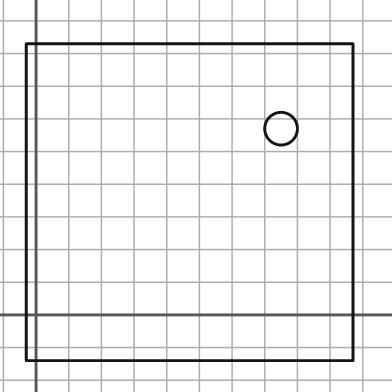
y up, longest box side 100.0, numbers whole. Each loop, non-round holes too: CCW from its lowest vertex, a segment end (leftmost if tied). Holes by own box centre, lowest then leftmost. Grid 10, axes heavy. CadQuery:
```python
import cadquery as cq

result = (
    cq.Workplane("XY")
    .moveTo(-3.0, -14.0)
    .lineTo(97.0, -14.0)
    .lineTo(97.0, 83.0)
    .lineTo(-3.0, 83.0)
    .close()
    .moveTo(75.0, 57.0)
    .circle(5.0)
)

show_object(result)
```